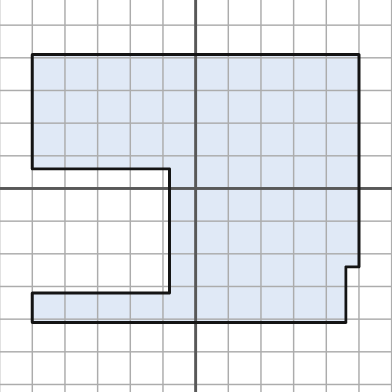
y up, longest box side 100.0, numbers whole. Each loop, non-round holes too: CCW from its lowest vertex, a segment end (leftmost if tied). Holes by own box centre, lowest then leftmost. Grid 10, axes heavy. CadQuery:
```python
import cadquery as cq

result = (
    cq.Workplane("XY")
    .moveTo(-50.0, -41.0)
    .lineTo(46.0, -41.0)
    .lineTo(46.0, -24.0)
    .lineTo(50.0, -24.0)
    .lineTo(50.0, 41.0)
    .lineTo(-50.0, 41.0)
    .lineTo(-50.0, 6.0)
    .lineTo(-8.0, 6.0)
    .lineTo(-8.0, -32.0)
    .lineTo(-50.0, -32.0)
    .close()
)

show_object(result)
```